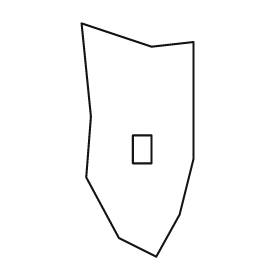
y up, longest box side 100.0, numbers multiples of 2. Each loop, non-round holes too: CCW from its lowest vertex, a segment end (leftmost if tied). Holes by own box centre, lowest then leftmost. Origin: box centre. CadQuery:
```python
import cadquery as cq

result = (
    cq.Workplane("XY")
    .moveTo(8.0, -50.0)
    .lineTo(18.0, -32.0)
    .lineTo(24.0, -8.0)
    .lineTo(24.0, 42.0)
    .lineTo(6.0, 40.0)
    .lineTo(-24.0, 50.0)
    .lineTo(-20.0, 10.0)
    .lineTo(-22.0, -16.0)
    .lineTo(-8.0, -42.0)
    .close()
    .moveTo(-2.0, -10.0)
    .lineTo(6.0, -10.0)
    .lineTo(6.0, 2.0)
    .lineTo(-2.0, 2.0)
    .close()
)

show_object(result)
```